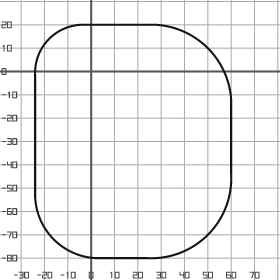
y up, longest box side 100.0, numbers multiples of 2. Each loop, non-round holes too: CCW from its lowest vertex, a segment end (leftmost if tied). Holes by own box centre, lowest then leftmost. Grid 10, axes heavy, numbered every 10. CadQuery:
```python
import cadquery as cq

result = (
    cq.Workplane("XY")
    .moveTo(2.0, -80.0)
    .lineTo(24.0, -80.0)
    .threePointArc((50.0, -70.0), (60.0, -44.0))
    .lineTo(60.0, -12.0)
    .threePointArc((50.0, 10.0), (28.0, 20.0))
    .lineTo(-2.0, 20.0)
    .threePointArc((-18.0, 14.0), (-24.0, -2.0))
    .lineTo(-24.0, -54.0)
    .threePointArc((-16.0, -72.0), (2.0, -80.0))
    .close()
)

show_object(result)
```